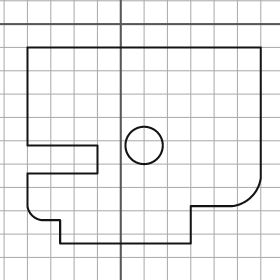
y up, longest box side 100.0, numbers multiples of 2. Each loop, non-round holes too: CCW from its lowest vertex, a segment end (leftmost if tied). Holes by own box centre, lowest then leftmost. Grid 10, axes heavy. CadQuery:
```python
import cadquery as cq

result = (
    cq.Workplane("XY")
    .moveTo(-26.0, -94.0)
    .lineTo(30.0, -94.0)
    .lineTo(30.0, -78.0)
    .lineTo(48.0, -78.0)
    .threePointArc((56.0, -74.0), (60.0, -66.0))
    .lineTo(60.0, -10.0)
    .lineTo(-40.0, -10.0)
    .lineTo(-40.0, -52.0)
    .lineTo(-10.0, -52.0)
    .lineTo(-10.0, -64.0)
    .lineTo(-40.0, -64.0)
    .lineTo(-40.0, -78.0)
    .threePointArc((-38.0, -82.0), (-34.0, -84.0))
    .lineTo(-26.0, -84.0)
    .close()
    .moveTo(10.0, -52.0)
    .circle(8.0)
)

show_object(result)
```